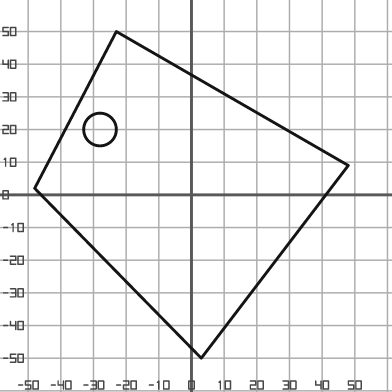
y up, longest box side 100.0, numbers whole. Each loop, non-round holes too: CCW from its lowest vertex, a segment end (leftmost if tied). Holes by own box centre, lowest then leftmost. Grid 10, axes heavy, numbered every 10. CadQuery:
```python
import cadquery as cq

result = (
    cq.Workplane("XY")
    .moveTo(3.0, -50.0)
    .lineTo(48.0, 9.0)
    .lineTo(-23.0, 50.0)
    .lineTo(-48.0, 2.0)
    .close()
    .moveTo(-28.0, 20.0)
    .circle(5.0)
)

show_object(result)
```